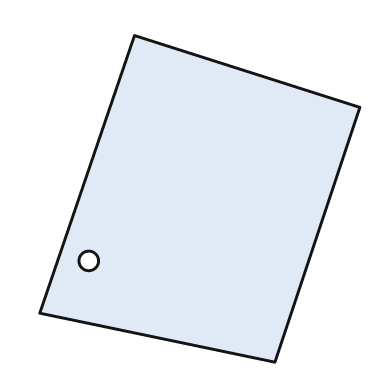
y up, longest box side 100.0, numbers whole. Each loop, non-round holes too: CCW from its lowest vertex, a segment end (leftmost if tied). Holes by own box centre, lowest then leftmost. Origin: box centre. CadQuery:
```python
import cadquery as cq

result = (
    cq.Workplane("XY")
    .moveTo(23.0, -50.0)
    .lineTo(49.0, 28.0)
    .lineTo(-20.0, 50.0)
    .lineTo(-49.0, -35.0)
    .close()
    .moveTo(-34.0, -19.0)
    .circle(3.0)
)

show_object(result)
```